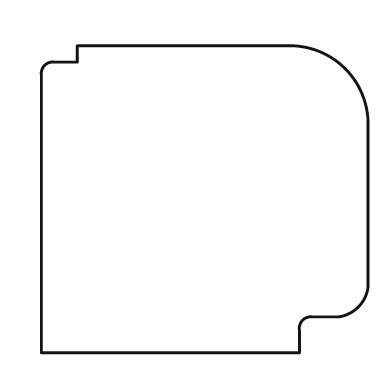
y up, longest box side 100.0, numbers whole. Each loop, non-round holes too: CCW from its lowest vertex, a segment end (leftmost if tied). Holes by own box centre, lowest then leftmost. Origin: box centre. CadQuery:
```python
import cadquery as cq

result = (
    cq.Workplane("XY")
    .moveTo(-50.0, -47.0)
    .lineTo(29.0, -47.0)
    .lineTo(29.0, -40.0)
    .threePointArc((30.0, -37.0), (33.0, -36.0))
    .lineTo(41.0, -36.0)
    .threePointArc((47.0, -33.0), (50.0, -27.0))
    .lineTo(50.0, 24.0)
    .threePointArc((43.0, 40.0), (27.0, 47.0))
    .lineTo(-39.0, 47.0)
    .lineTo(-39.0, 42.0)
    .lineTo(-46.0, 42.0)
    .threePointArc((-49.0, 41.0), (-50.0, 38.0))
    .close()
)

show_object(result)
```